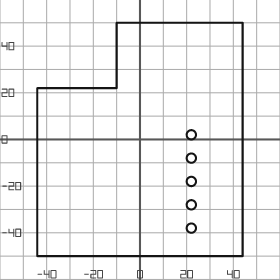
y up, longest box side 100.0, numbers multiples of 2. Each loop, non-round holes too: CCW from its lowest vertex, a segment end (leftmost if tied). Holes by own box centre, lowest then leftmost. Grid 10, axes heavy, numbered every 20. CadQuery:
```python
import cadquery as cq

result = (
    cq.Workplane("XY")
    .moveTo(-44.0, -50.0)
    .lineTo(44.0, -50.0)
    .lineTo(44.0, 50.0)
    .lineTo(-10.0, 50.0)
    .lineTo(-10.0, 22.0)
    .lineTo(-44.0, 22.0)
    .close()
    .moveTo(22.0, -38.0)
    .circle(2.0)
    .moveTo(22.0, -28.0)
    .circle(2.0)
    .moveTo(22.0, -18.0)
    .circle(2.0)
    .moveTo(22.0, -8.0)
    .circle(2.0)
    .moveTo(22.0, 2.0)
    .circle(2.0)
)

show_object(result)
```